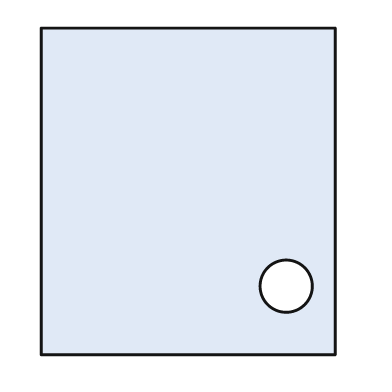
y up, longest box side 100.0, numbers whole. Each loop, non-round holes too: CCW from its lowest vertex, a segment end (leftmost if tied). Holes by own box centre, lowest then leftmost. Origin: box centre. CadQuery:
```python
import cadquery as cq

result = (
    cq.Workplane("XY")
    .moveTo(-45.0, -50.0)
    .lineTo(45.0, -50.0)
    .lineTo(45.0, 50.0)
    .lineTo(-45.0, 50.0)
    .close()
    .moveTo(30.0, -29.0)
    .circle(8.0)
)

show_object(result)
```